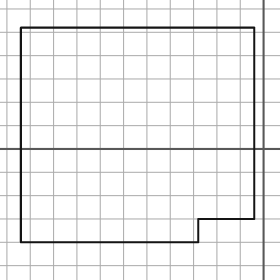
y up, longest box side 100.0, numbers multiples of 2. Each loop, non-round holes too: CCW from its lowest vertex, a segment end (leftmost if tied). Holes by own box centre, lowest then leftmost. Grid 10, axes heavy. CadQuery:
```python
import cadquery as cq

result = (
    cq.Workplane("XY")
    .moveTo(-104.0, -40.0)
    .lineTo(-28.0, -40.0)
    .lineTo(-28.0, -30.0)
    .lineTo(-4.0, -30.0)
    .lineTo(-4.0, 52.0)
    .lineTo(-104.0, 52.0)
    .close()
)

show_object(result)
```